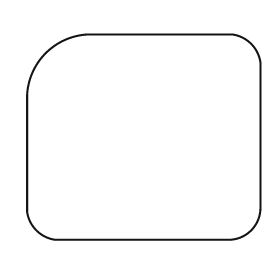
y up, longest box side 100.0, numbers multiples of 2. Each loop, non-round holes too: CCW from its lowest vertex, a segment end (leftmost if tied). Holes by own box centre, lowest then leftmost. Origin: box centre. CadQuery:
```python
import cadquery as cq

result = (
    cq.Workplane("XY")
    .moveTo(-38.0, -44.0)
    .lineTo(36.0, -44.0)
    .threePointArc((46.0, -40.0), (50.0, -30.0))
    .lineTo(50.0, 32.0)
    .threePointArc((46.0, 40.0), (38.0, 44.0))
    .lineTo(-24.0, 44.0)
    .threePointArc((-42.0, 36.0), (-50.0, 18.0))
    .lineTo(-50.0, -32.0)
    .threePointArc((-46.0, -40.0), (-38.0, -44.0))
    .close()
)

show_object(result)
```